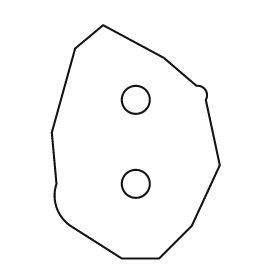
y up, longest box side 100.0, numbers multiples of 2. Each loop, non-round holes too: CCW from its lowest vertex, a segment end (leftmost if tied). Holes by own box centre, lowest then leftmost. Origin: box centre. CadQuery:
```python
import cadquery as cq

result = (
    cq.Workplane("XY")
    .moveTo(-6.0, -50.0)
    .lineTo(10.0, -50.0)
    .lineTo(24.0, -36.0)
    .lineTo(36.0, -10.0)
    .lineTo(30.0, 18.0)
    .threePointArc((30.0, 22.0), (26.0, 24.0))
    .lineTo(12.0, 36.0)
    .lineTo(-14.0, 50.0)
    .lineTo(-26.0, 40.0)
    .lineTo(-36.0, 4.0)
    .lineTo(-34.0, -18.0)
    .threePointArc((-34.0, -28.0), (-28.0, -36.0))
    .close()
    .moveTo(0.0, -18.0)
    .circle(6.0)
    .moveTo(0.0, 18.0)
    .circle(6.0)
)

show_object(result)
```